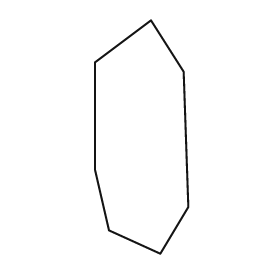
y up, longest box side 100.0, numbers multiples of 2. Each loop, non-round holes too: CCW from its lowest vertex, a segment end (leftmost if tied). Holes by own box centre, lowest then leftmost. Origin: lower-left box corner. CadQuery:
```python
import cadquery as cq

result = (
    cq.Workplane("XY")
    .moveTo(28.0, 0.0)
    .lineTo(40.0, 20.0)
    .lineTo(38.0, 78.0)
    .lineTo(24.0, 100.0)
    .lineTo(0.0, 82.0)
    .lineTo(0.0, 36.0)
    .lineTo(6.0, 10.0)
    .close()
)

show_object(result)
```